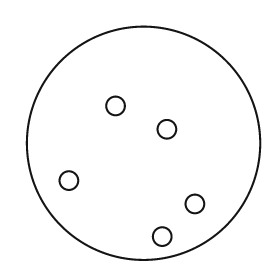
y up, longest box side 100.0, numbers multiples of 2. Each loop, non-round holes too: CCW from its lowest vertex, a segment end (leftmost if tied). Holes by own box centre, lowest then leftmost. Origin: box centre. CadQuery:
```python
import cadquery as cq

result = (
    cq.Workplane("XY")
    .moveTo(0.0, 0.0)
    .circle(50.0)
    .moveTo(8.0, -40.0)
    .circle(4.0)
    .moveTo(22.0, -26.0)
    .circle(4.0)
    .moveTo(-32.0, -16.0)
    .circle(4.0)
    .moveTo(10.0, 6.0)
    .circle(4.0)
    .moveTo(-12.0, 16.0)
    .circle(4.0)
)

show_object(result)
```